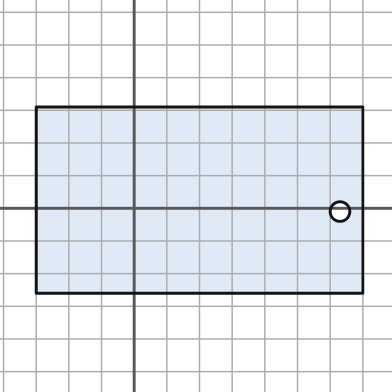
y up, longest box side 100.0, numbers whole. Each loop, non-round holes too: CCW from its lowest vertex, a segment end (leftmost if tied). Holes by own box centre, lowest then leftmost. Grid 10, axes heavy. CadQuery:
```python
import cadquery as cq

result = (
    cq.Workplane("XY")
    .moveTo(-30.0, -26.0)
    .lineTo(70.0, -26.0)
    .lineTo(70.0, 31.0)
    .lineTo(-30.0, 31.0)
    .close()
    .moveTo(63.0, -1.0)
    .circle(3.0)
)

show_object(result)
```